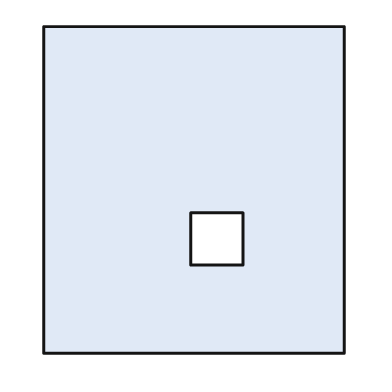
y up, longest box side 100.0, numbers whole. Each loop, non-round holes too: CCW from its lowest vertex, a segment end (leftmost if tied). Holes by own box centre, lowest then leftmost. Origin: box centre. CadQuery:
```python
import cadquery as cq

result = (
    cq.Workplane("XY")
    .moveTo(-46.0, -50.0)
    .lineTo(46.0, -50.0)
    .lineTo(46.0, 50.0)
    .lineTo(-46.0, 50.0)
    .close()
    .moveTo(-1.0, -23.0)
    .lineTo(15.0, -23.0)
    .lineTo(15.0, -7.0)
    .lineTo(-1.0, -7.0)
    .close()
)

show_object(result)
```